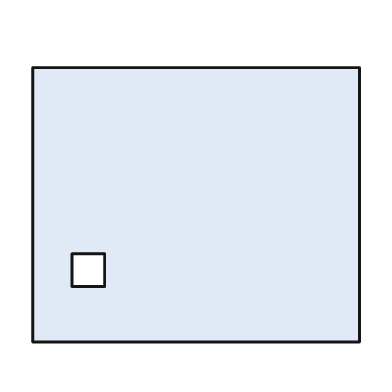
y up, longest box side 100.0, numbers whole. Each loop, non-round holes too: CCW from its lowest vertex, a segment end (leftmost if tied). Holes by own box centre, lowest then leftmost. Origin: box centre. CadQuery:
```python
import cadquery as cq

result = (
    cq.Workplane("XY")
    .moveTo(-50.0, -42.0)
    .lineTo(50.0, -42.0)
    .lineTo(50.0, 42.0)
    .lineTo(-50.0, 42.0)
    .close()
    .moveTo(-38.0, -25.0)
    .lineTo(-28.0, -25.0)
    .lineTo(-28.0, -15.0)
    .lineTo(-38.0, -15.0)
    .close()
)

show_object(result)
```